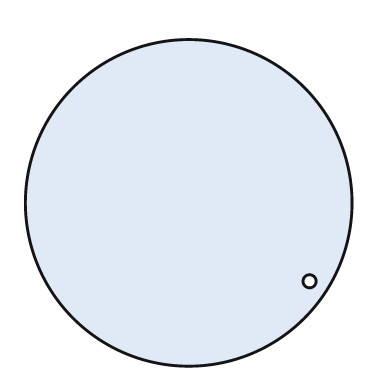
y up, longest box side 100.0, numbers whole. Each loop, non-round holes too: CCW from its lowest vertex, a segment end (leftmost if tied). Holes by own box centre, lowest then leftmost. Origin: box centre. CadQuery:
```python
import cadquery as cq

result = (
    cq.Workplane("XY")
    .moveTo(0.0, 0.0)
    .circle(50.0)
    .moveTo(37.0, -24.0)
    .circle(2.0)
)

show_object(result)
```